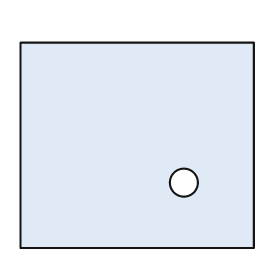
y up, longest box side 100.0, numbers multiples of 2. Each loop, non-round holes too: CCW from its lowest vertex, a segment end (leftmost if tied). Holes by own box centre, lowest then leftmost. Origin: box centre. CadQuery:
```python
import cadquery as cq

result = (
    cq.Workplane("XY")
    .moveTo(-50.0, -44.0)
    .lineTo(50.0, -44.0)
    .lineTo(50.0, 44.0)
    .lineTo(-50.0, 44.0)
    .close()
    .moveTo(20.0, -16.0)
    .circle(6.0)
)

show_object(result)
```